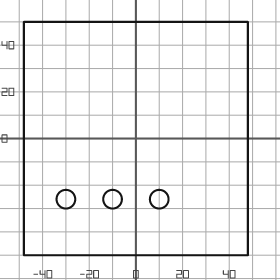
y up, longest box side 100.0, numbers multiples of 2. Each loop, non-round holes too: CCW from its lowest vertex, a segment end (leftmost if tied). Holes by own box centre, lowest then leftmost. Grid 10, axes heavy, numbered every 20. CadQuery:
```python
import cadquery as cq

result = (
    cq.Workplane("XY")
    .moveTo(-48.0, -50.0)
    .lineTo(48.0, -50.0)
    .lineTo(48.0, 50.0)
    .lineTo(-48.0, 50.0)
    .close()
    .moveTo(-30.0, -26.0)
    .circle(4.0)
    .moveTo(-10.0, -26.0)
    .circle(4.0)
    .moveTo(10.0, -26.0)
    .circle(4.0)
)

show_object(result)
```